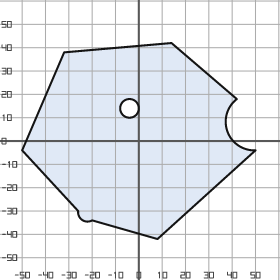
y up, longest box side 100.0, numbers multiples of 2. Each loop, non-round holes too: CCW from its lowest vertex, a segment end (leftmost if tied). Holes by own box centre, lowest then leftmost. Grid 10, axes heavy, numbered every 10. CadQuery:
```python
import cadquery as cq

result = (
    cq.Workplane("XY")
    .moveTo(8.0, -42.0)
    .lineTo(50.0, -4.0)
    .threePointArc((38.0, 4.0), (42.0, 18.0))
    .lineTo(14.0, 42.0)
    .lineTo(-32.0, 38.0)
    .lineTo(-50.0, -4.0)
    .lineTo(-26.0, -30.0)
    .threePointArc((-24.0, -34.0), (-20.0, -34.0))
    .close()
    .moveTo(-4.0, 14.0)
    .circle(4.0)
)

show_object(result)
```